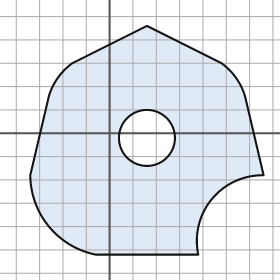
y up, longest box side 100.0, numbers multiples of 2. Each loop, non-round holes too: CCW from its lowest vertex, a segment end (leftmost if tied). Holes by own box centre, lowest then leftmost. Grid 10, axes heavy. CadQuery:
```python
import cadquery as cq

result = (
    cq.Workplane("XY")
    .moveTo(-6.0, -52.0)
    .lineTo(38.0, -52.0)
    .threePointArc((44.0, -28.0), (66.0, -18.0))
    .lineTo(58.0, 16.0)
    .threePointArc((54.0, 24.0), (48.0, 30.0))
    .lineTo(16.0, 46.0)
    .lineTo(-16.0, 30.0)
    .threePointArc((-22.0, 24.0), (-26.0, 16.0))
    .lineTo(-34.0, -18.0)
    .threePointArc((-26.0, -40.0), (-6.0, -52.0))
    .close()
    .moveTo(16.0, -2.0)
    .circle(12.0)
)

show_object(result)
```